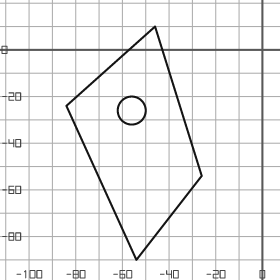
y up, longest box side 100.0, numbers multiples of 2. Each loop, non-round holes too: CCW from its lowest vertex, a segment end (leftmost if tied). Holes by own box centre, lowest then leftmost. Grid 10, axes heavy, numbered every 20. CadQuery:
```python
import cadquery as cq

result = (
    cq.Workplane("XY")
    .moveTo(-54.0, -90.0)
    .lineTo(-26.0, -54.0)
    .lineTo(-46.0, 10.0)
    .lineTo(-84.0, -24.0)
    .close()
    .moveTo(-56.0, -26.0)
    .circle(6.0)
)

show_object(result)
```